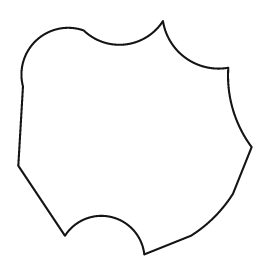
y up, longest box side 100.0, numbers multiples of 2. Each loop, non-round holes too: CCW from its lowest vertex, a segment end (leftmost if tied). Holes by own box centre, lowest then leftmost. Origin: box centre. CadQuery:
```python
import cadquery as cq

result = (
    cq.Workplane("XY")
    .moveTo(4.0, -50.0)
    .lineTo(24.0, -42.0)
    .threePointArc((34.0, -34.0), (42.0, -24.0))
    .lineTo(50.0, -4.0)
    .threePointArc((42.0, 12.0), (40.0, 30.0))
    .threePointArc((22.0, 34.0), (12.0, 50.0))
    .threePointArc((-4.0, 40.0), (-22.0, 46.0))
    .threePointArc((-42.0, 42.0), (-48.0, 22.0))
    .lineTo(-50.0, -12.0)
    .lineTo(-30.0, -42.0)
    .threePointArc((-10.0, -34.0), (4.0, -50.0))
    .close()
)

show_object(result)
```